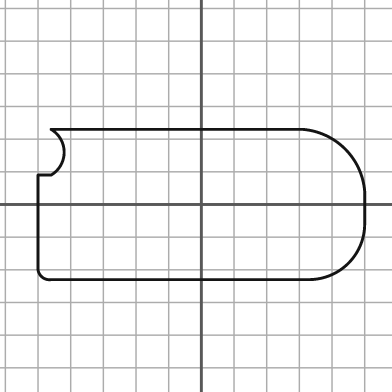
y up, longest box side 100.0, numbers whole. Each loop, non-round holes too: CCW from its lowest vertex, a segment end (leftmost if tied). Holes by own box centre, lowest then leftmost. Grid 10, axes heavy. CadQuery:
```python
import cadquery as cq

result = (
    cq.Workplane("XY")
    .moveTo(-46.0, -23.0)
    .lineTo(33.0, -23.0)
    .threePointArc((45.0, -18.0), (50.0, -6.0))
    .lineTo(50.0, 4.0)
    .threePointArc((44.0, 17.0), (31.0, 23.0))
    .lineTo(-46.0, 23.0)
    .threePointArc((-42.0, 16.0), (-46.0, 9.0))
    .lineTo(-50.0, 9.0)
    .lineTo(-50.0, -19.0)
    .threePointArc((-49.0, -22.0), (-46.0, -23.0))
    .close()
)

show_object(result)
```